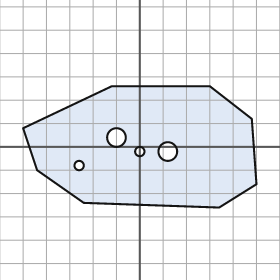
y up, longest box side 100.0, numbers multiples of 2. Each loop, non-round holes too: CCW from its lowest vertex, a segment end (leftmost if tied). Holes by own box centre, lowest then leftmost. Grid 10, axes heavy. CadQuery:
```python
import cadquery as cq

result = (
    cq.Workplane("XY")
    .moveTo(34.0, -26.0)
    .lineTo(50.0, -16.0)
    .lineTo(48.0, 12.0)
    .lineTo(30.0, 26.0)
    .lineTo(-12.0, 26.0)
    .lineTo(-50.0, 8.0)
    .lineTo(-44.0, -10.0)
    .lineTo(-24.0, -24.0)
    .close()
    .moveTo(-26.0, -8.0)
    .circle(2.0)
    .moveTo(0.0, -2.0)
    .circle(2.0)
    .moveTo(12.0, -2.0)
    .circle(4.0)
    .moveTo(-10.0, 4.0)
    .circle(4.0)
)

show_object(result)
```